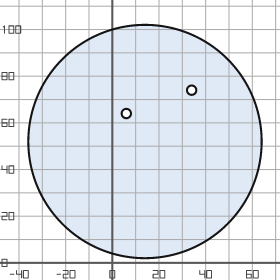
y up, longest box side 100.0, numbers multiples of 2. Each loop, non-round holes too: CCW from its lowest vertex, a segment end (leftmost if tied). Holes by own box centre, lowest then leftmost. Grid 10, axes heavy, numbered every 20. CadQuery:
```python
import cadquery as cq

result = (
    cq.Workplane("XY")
    .moveTo(14.0, 52.0)
    .circle(50.0)
    .moveTo(6.0, 64.0)
    .circle(2.0)
    .moveTo(34.0, 74.0)
    .circle(2.0)
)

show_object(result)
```